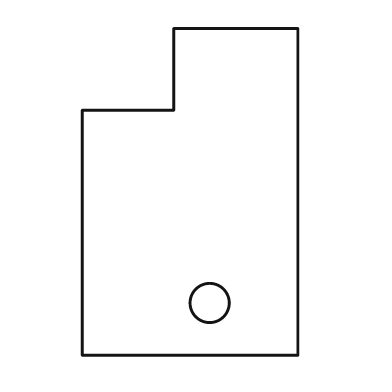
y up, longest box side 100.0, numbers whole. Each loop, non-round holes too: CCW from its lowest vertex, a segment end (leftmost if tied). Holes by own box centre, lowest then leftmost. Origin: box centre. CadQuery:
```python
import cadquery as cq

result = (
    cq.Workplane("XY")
    .moveTo(-33.0, -50.0)
    .lineTo(33.0, -50.0)
    .lineTo(33.0, 50.0)
    .lineTo(-5.0, 50.0)
    .lineTo(-5.0, 25.0)
    .lineTo(-33.0, 25.0)
    .close()
    .moveTo(6.0, -34.0)
    .circle(6.0)
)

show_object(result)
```